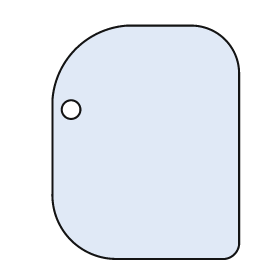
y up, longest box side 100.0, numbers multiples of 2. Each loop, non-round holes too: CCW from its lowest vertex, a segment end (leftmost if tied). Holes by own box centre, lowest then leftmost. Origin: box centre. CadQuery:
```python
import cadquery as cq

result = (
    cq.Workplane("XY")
    .moveTo(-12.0, -50.0)
    .lineTo(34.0, -50.0)
    .threePointArc((38.0, -48.0), (40.0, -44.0))
    .lineTo(40.0, 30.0)
    .threePointArc((34.0, 44.0), (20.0, 50.0))
    .lineTo(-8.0, 50.0)
    .threePointArc((-30.0, 40.0), (-40.0, 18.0))
    .lineTo(-40.0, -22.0)
    .threePointArc((-32.0, -42.0), (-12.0, -50.0))
    .close()
    .moveTo(-32.0, 14.0)
    .circle(4.0)
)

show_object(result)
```